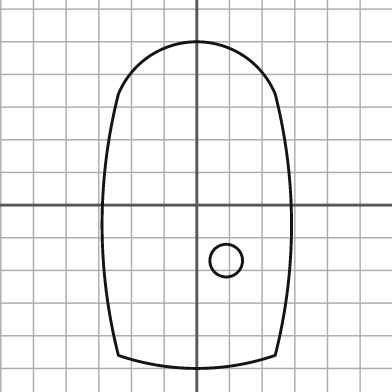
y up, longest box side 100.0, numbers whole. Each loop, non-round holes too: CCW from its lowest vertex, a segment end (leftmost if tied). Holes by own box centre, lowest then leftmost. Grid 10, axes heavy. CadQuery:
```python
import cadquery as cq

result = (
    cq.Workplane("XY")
    .moveTo(-24.0, -46.0)
    .threePointArc((0.0, -50.0), (24.0, -46.0))
    .threePointArc((29.0, -6.0), (24.0, 34.0))
    .threePointArc((0.0, 50.0), (-24.0, 34.0))
    .threePointArc((-29.0, -6.0), (-24.0, -46.0))
    .close()
    .moveTo(9.0, -17.0)
    .circle(5.0)
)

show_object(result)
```